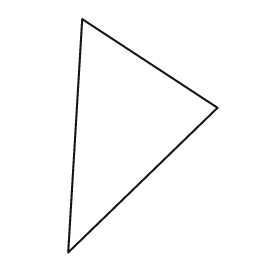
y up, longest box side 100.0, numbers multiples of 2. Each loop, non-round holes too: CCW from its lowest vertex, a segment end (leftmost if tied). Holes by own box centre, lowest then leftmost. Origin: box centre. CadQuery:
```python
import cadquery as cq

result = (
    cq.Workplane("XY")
    .moveTo(-32.0, -50.0)
    .lineTo(32.0, 12.0)
    .lineTo(-26.0, 50.0)
    .close()
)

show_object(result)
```